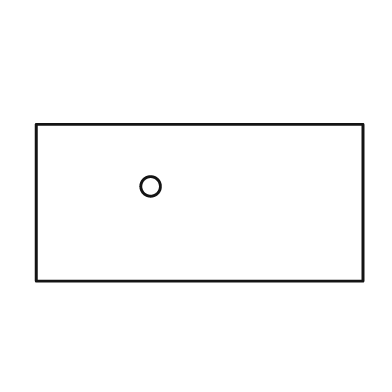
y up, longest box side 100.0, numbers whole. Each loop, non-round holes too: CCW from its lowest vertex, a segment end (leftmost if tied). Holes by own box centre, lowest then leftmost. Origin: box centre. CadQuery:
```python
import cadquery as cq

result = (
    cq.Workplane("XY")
    .moveTo(-50.0, -24.0)
    .lineTo(50.0, -24.0)
    .lineTo(50.0, 24.0)
    .lineTo(-50.0, 24.0)
    .close()
    .moveTo(-15.0, 5.0)
    .circle(3.0)
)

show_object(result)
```